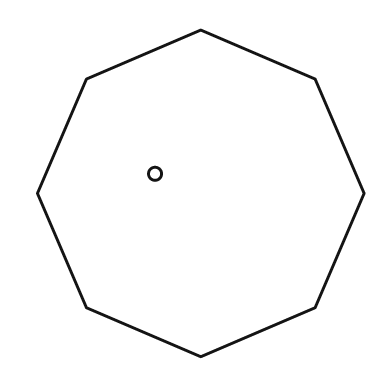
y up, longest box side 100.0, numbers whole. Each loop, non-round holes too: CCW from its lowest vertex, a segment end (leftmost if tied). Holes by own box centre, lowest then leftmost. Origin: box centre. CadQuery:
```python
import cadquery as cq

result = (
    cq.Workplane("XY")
    .moveTo(0.0, -50.0)
    .lineTo(35.0, -35.0)
    .lineTo(50.0, 0.0)
    .lineTo(35.0, 35.0)
    .lineTo(0.0, 50.0)
    .lineTo(-35.0, 35.0)
    .lineTo(-50.0, 0.0)
    .lineTo(-35.0, -35.0)
    .close()
    .moveTo(-14.0, 6.0)
    .circle(2.0)
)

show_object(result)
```